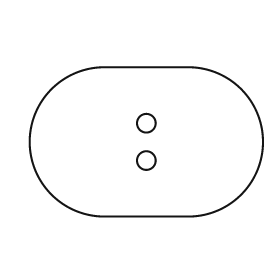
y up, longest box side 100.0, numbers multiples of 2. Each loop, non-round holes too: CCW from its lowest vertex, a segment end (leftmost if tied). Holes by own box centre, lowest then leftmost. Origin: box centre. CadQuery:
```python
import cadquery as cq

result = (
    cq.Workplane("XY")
    .moveTo(-18.0, -32.0)
    .lineTo(18.0, -32.0)
    .threePointArc((50.0, 0.0), (18.0, 32.0))
    .lineTo(-18.0, 32.0)
    .threePointArc((-50.0, 0.0), (-18.0, -32.0))
    .close()
    .moveTo(0.0, -8.0)
    .circle(4.0)
    .moveTo(0.0, 8.0)
    .circle(4.0)
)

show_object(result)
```